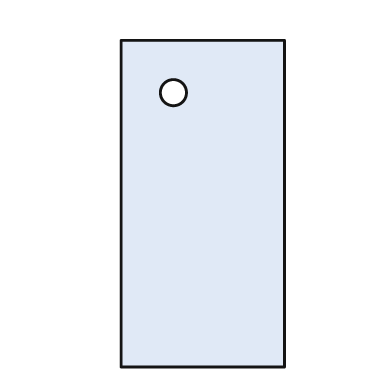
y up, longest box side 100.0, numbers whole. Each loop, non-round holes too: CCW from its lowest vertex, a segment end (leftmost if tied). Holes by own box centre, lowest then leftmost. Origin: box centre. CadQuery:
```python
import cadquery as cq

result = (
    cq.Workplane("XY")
    .moveTo(-25.0, -50.0)
    .lineTo(25.0, -50.0)
    .lineTo(25.0, 50.0)
    .lineTo(-25.0, 50.0)
    .close()
    .moveTo(-9.0, 34.0)
    .circle(4.0)
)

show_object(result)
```